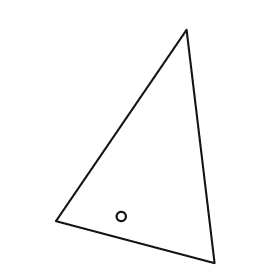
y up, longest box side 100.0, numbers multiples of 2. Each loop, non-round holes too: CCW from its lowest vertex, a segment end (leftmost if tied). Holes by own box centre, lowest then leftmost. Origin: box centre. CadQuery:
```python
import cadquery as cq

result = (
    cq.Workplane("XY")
    .moveTo(34.0, -50.0)
    .lineTo(22.0, 50.0)
    .lineTo(-34.0, -32.0)
    .close()
    .moveTo(-6.0, -30.0)
    .circle(2.0)
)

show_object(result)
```